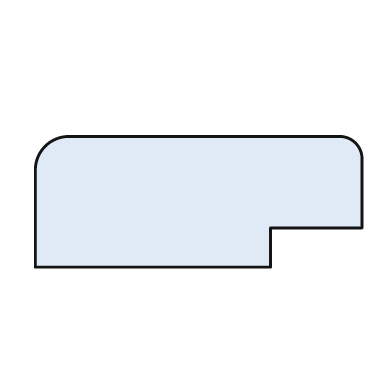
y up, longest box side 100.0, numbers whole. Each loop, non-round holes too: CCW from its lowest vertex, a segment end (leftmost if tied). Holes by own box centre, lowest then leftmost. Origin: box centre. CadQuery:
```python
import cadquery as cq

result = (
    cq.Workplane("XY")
    .moveTo(-50.0, -20.0)
    .lineTo(22.0, -20.0)
    .lineTo(22.0, -8.0)
    .lineTo(50.0, -8.0)
    .lineTo(50.0, 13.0)
    .threePointArc((48.0, 18.0), (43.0, 20.0))
    .lineTo(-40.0, 20.0)
    .threePointArc((-47.0, 17.0), (-50.0, 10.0))
    .close()
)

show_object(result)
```